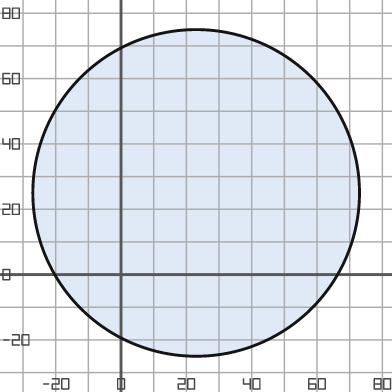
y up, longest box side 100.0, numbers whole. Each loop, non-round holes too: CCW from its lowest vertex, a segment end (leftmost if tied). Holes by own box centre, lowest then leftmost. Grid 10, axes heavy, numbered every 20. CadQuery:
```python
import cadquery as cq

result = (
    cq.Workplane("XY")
    .moveTo(23.0, 25.0)
    .circle(50.0)
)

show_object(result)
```